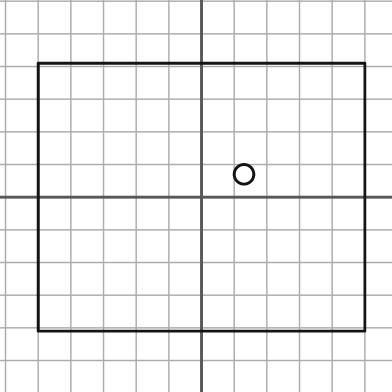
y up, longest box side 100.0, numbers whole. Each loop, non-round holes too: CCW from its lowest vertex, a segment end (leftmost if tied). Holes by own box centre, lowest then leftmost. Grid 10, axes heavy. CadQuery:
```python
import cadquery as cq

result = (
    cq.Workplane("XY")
    .moveTo(-50.0, -41.0)
    .lineTo(50.0, -41.0)
    .lineTo(50.0, 41.0)
    .lineTo(-50.0, 41.0)
    .close()
    .moveTo(13.0, 7.0)
    .circle(3.0)
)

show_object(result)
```